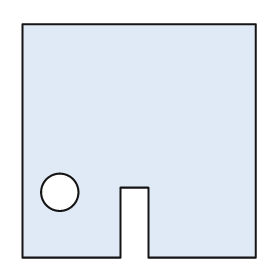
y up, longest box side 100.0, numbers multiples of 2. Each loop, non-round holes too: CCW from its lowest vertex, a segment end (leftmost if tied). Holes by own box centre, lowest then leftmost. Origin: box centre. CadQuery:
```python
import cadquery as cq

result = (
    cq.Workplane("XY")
    .moveTo(-50.0, -50.0)
    .lineTo(-8.0, -50.0)
    .lineTo(-8.0, -20.0)
    .lineTo(4.0, -20.0)
    .lineTo(4.0, -50.0)
    .lineTo(50.0, -50.0)
    .lineTo(50.0, 50.0)
    .lineTo(-50.0, 50.0)
    .close()
    .moveTo(-34.0, -22.0)
    .circle(8.0)
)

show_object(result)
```